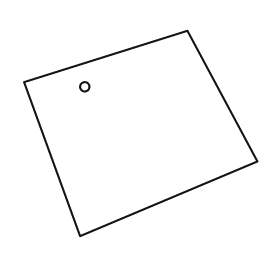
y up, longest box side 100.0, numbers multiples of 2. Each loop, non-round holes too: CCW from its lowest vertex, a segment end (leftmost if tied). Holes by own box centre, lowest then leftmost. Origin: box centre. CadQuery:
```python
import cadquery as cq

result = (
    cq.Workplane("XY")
    .moveTo(-26.0, -44.0)
    .lineTo(50.0, -12.0)
    .lineTo(20.0, 44.0)
    .lineTo(-50.0, 22.0)
    .close()
    .moveTo(-24.0, 20.0)
    .circle(2.0)
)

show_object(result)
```